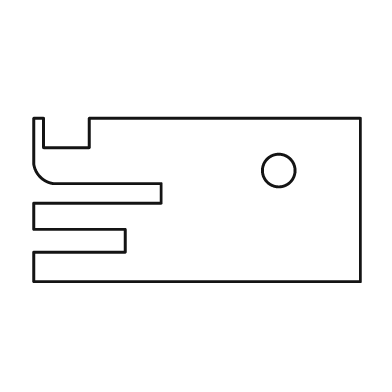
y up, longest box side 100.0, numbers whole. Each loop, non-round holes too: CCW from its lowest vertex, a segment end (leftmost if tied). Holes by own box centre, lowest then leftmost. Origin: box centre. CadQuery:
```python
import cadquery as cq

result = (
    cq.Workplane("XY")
    .moveTo(-50.0, -25.0)
    .lineTo(50.0, -25.0)
    .lineTo(50.0, 25.0)
    .lineTo(-33.0, 25.0)
    .lineTo(-33.0, 16.0)
    .lineTo(-47.0, 16.0)
    .lineTo(-47.0, 25.0)
    .lineTo(-50.0, 25.0)
    .lineTo(-50.0, 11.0)
    .threePointArc((-48.0, 7.0), (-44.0, 5.0))
    .lineTo(-11.0, 5.0)
    .lineTo(-11.0, -1.0)
    .lineTo(-50.0, -1.0)
    .lineTo(-50.0, -9.0)
    .lineTo(-22.0, -9.0)
    .lineTo(-22.0, -16.0)
    .lineTo(-50.0, -16.0)
    .close()
    .moveTo(25.0, 9.0)
    .circle(5.0)
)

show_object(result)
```